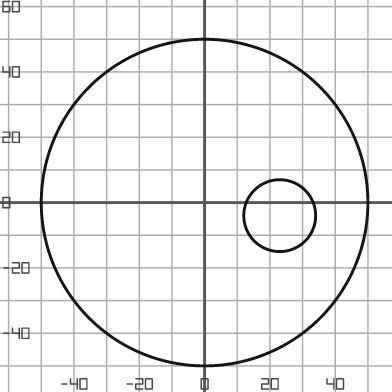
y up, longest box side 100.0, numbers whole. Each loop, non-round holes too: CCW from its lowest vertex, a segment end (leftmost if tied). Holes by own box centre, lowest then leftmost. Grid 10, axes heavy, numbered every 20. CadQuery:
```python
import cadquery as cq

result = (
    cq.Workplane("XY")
    .moveTo(0.0, 0.0)
    .circle(50.0)
    .moveTo(23.0, -4.0)
    .circle(11.0)
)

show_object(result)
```